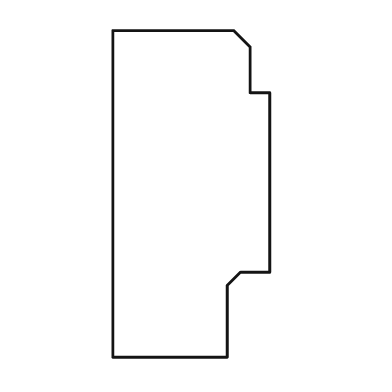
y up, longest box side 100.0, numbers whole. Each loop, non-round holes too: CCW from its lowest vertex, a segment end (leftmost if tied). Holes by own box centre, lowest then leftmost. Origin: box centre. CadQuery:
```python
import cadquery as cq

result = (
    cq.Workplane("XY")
    .moveTo(-24.0, -50.0)
    .lineTo(11.0, -50.0)
    .lineTo(11.0, -28.0)
    .lineTo(15.0, -24.0)
    .lineTo(24.0, -24.0)
    .lineTo(24.0, 31.0)
    .lineTo(18.0, 31.0)
    .lineTo(18.0, 45.0)
    .lineTo(13.0, 50.0)
    .lineTo(-24.0, 50.0)
    .close()
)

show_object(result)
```